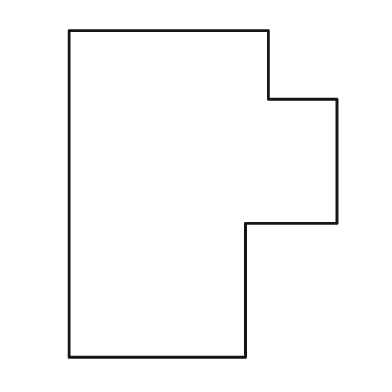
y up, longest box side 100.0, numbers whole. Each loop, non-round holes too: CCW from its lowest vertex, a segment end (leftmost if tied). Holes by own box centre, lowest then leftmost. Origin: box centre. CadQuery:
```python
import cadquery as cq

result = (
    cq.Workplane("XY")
    .moveTo(-41.0, -50.0)
    .lineTo(13.0, -50.0)
    .lineTo(13.0, -9.0)
    .lineTo(41.0, -9.0)
    .lineTo(41.0, 29.0)
    .lineTo(20.0, 29.0)
    .lineTo(20.0, 50.0)
    .lineTo(-41.0, 50.0)
    .close()
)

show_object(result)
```